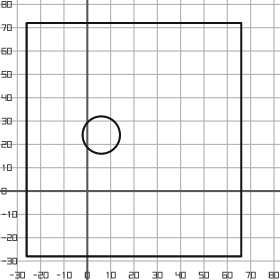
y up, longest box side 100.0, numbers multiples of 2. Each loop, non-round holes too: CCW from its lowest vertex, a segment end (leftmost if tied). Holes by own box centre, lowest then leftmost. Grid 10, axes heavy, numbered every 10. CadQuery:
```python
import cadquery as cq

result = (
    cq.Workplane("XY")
    .moveTo(-26.0, -28.0)
    .lineTo(66.0, -28.0)
    .lineTo(66.0, 72.0)
    .lineTo(-26.0, 72.0)
    .close()
    .moveTo(6.0, 24.0)
    .circle(8.0)
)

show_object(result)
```